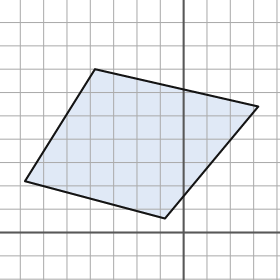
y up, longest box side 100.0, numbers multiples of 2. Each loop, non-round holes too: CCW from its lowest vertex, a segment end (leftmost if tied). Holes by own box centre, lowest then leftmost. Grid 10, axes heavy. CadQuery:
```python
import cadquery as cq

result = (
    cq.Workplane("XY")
    .moveTo(-8.0, 6.0)
    .lineTo(32.0, 54.0)
    .lineTo(-38.0, 70.0)
    .lineTo(-68.0, 22.0)
    .close()
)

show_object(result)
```